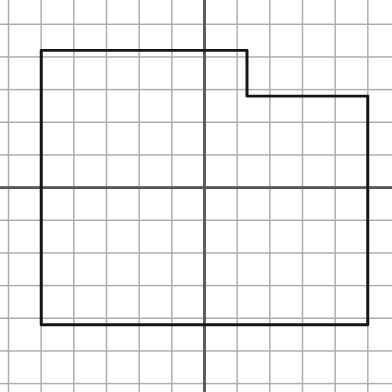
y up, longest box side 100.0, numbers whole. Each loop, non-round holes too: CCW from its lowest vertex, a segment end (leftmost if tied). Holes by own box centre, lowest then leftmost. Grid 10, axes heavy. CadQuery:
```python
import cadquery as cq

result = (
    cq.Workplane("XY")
    .moveTo(-50.0, -42.0)
    .lineTo(50.0, -42.0)
    .lineTo(50.0, 28.0)
    .lineTo(13.0, 28.0)
    .lineTo(13.0, 42.0)
    .lineTo(-50.0, 42.0)
    .close()
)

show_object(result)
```